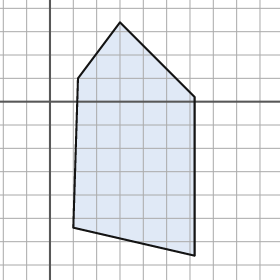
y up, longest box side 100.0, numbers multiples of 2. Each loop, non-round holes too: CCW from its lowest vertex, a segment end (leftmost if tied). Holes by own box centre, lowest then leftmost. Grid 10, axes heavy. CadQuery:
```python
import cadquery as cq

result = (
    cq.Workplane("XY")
    .moveTo(62.0, -66.0)
    .lineTo(62.0, 2.0)
    .lineTo(30.0, 34.0)
    .lineTo(12.0, 10.0)
    .lineTo(10.0, -54.0)
    .close()
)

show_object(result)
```